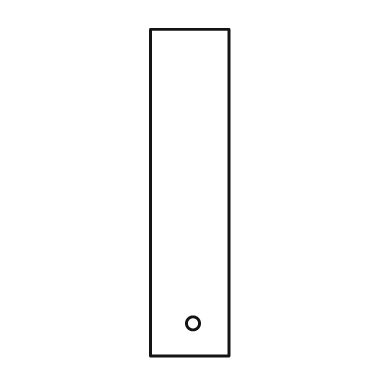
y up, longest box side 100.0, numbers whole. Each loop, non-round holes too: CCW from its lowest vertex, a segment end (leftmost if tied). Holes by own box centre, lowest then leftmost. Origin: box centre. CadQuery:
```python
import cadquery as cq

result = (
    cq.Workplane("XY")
    .moveTo(-12.0, -50.0)
    .lineTo(12.0, -50.0)
    .lineTo(12.0, 50.0)
    .lineTo(-12.0, 50.0)
    .close()
    .moveTo(1.0, -40.0)
    .circle(2.0)
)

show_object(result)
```